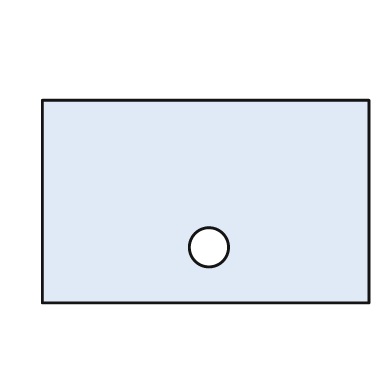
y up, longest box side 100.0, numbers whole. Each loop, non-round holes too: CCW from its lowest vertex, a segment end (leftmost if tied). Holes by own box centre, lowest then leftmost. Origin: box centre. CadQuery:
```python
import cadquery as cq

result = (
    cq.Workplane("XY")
    .moveTo(-50.0, -31.0)
    .lineTo(50.0, -31.0)
    .lineTo(50.0, 31.0)
    .lineTo(-50.0, 31.0)
    .close()
    .moveTo(1.0, -14.0)
    .circle(6.0)
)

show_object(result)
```